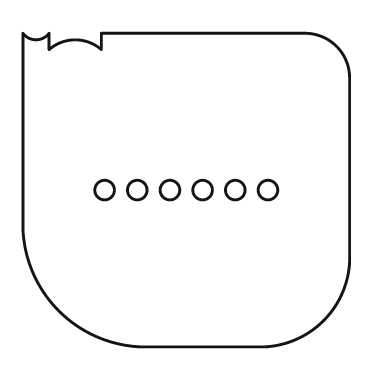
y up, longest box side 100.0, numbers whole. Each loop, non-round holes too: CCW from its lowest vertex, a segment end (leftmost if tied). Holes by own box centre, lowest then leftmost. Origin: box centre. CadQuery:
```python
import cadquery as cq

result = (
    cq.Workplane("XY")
    .moveTo(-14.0, -48.0)
    .lineTo(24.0, -48.0)
    .threePointArc((42.0, -40.0), (50.0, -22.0))
    .lineTo(50.0, 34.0)
    .threePointArc((46.0, 44.0), (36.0, 48.0))
    .lineTo(-26.0, 48.0)
    .lineTo(-26.0, 43.0)
    .threePointArc((-34.0, 46.0), (-42.0, 43.0))
    .lineTo(-42.0, 48.0)
    .threePointArc((-46.0, 46.0), (-50.0, 48.0))
    .lineTo(-50.0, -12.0)
    .threePointArc((-39.0, -37.0), (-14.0, -48.0))
    .close()
    .moveTo(-25.0, 0.0)
    .circle(3.0)
    .moveTo(-15.0, 0.0)
    .circle(3.0)
    .moveTo(-5.0, 0.0)
    .circle(3.0)
    .moveTo(5.0, 0.0)
    .circle(3.0)
    .moveTo(15.0, 0.0)
    .circle(3.0)
    .moveTo(25.0, 0.0)
    .circle(3.0)
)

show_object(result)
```